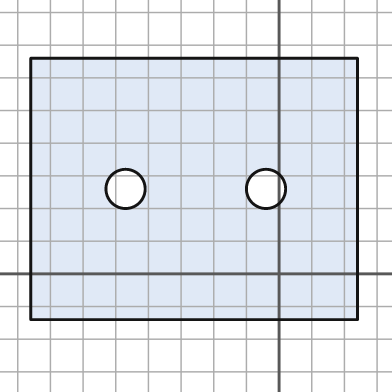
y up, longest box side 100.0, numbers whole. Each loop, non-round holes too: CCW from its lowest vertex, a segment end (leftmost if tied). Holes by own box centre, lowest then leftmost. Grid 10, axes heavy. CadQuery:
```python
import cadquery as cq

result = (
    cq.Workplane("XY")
    .moveTo(-76.0, -14.0)
    .lineTo(24.0, -14.0)
    .lineTo(24.0, 66.0)
    .lineTo(-76.0, 66.0)
    .close()
    .moveTo(-47.0, 26.0)
    .circle(6.0)
    .moveTo(-4.0, 26.0)
    .circle(6.0)
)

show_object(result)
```